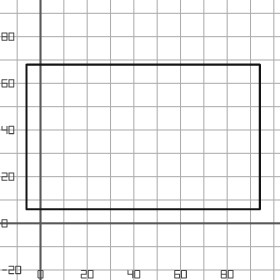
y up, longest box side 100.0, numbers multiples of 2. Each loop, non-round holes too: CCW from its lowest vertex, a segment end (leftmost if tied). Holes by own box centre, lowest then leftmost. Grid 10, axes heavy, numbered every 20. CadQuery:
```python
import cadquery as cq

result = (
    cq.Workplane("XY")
    .moveTo(-6.0, 6.0)
    .lineTo(94.0, 6.0)
    .lineTo(94.0, 68.0)
    .lineTo(-6.0, 68.0)
    .close()
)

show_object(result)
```